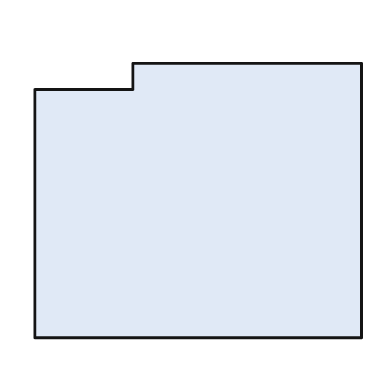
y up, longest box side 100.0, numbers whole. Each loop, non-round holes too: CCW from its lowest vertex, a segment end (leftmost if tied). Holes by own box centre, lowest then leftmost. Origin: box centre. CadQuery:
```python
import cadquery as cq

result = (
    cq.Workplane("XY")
    .moveTo(-50.0, -42.0)
    .lineTo(50.0, -42.0)
    .lineTo(50.0, 42.0)
    .lineTo(-20.0, 42.0)
    .lineTo(-20.0, 34.0)
    .lineTo(-50.0, 34.0)
    .close()
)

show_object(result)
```